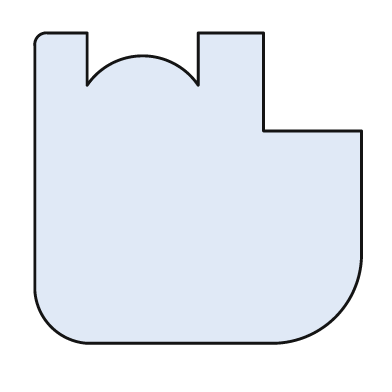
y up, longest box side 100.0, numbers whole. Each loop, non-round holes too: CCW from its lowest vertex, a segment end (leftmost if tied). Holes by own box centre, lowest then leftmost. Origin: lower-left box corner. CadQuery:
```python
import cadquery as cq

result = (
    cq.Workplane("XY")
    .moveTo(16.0, 0.0)
    .lineTo(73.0, 0.0)
    .threePointArc((92.0, 8.0), (100.0, 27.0))
    .lineTo(100.0, 65.0)
    .lineTo(70.0, 65.0)
    .lineTo(70.0, 95.0)
    .lineTo(50.0, 95.0)
    .lineTo(50.0, 79.0)
    .threePointArc((33.0, 88.0), (16.0, 79.0))
    .lineTo(16.0, 95.0)
    .lineTo(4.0, 95.0)
    .threePointArc((1.0, 94.0), (0.0, 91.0))
    .lineTo(0.0, 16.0)
    .threePointArc((5.0, 5.0), (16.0, 0.0))
    .close()
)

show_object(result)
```